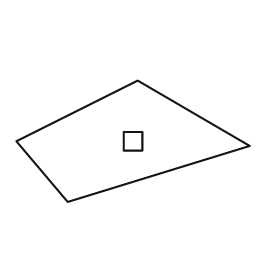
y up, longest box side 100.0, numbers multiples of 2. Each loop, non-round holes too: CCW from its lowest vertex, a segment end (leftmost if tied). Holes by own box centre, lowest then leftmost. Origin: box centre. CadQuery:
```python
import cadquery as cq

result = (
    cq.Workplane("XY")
    .moveTo(-28.0, -26.0)
    .lineTo(50.0, -2.0)
    .lineTo(2.0, 26.0)
    .lineTo(-50.0, 0.0)
    .close()
    .moveTo(-4.0, -4.0)
    .lineTo(4.0, -4.0)
    .lineTo(4.0, 4.0)
    .lineTo(-4.0, 4.0)
    .close()
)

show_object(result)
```